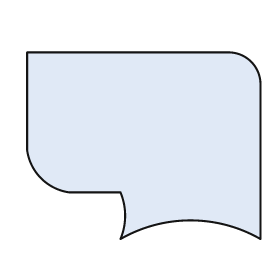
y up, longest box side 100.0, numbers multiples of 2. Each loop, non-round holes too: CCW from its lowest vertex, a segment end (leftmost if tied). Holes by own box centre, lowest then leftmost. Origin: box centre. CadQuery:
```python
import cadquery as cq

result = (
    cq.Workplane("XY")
    .moveTo(-10.0, -40.0)
    .threePointArc((20.0, -32.0), (50.0, -40.0))
    .lineTo(50.0, 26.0)
    .threePointArc((46.0, 36.0), (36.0, 40.0))
    .lineTo(-50.0, 40.0)
    .lineTo(-50.0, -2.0)
    .threePointArc((-44.0, -14.0), (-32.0, -20.0))
    .lineTo(-10.0, -20.0)
    .threePointArc((-8.0, -30.0), (-10.0, -40.0))
    .close()
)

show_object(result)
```